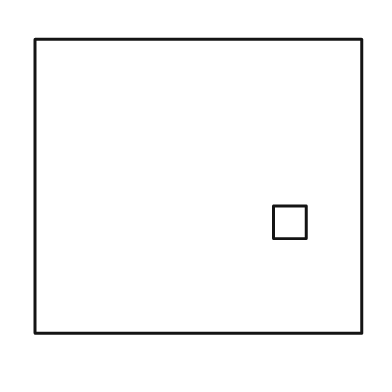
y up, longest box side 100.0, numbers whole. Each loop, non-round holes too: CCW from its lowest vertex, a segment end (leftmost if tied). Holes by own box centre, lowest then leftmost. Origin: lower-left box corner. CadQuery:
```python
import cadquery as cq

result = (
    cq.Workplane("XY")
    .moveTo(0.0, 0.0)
    .lineTo(100.0, 0.0)
    .lineTo(100.0, 90.0)
    .lineTo(0.0, 90.0)
    .close()
    .moveTo(73.0, 29.0)
    .lineTo(83.0, 29.0)
    .lineTo(83.0, 39.0)
    .lineTo(73.0, 39.0)
    .close()
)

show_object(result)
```